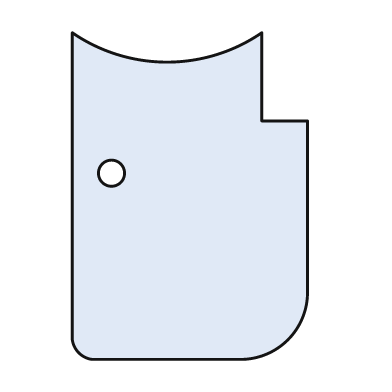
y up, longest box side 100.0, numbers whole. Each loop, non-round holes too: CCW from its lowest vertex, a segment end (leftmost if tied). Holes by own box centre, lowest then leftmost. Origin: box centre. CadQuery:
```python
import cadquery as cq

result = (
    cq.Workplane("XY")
    .moveTo(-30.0, -50.0)
    .lineTo(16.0, -50.0)
    .threePointArc((30.0, -44.0), (36.0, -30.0))
    .lineTo(36.0, 23.0)
    .lineTo(22.0, 23.0)
    .lineTo(22.0, 50.0)
    .threePointArc((-7.0, 41.0), (-36.0, 50.0))
    .lineTo(-36.0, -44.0)
    .threePointArc((-34.0, -48.0), (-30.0, -50.0))
    .close()
    .moveTo(-24.0, 7.0)
    .circle(4.0)
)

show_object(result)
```